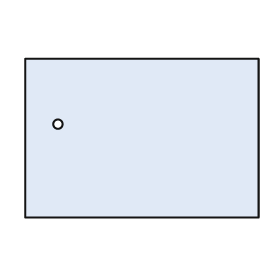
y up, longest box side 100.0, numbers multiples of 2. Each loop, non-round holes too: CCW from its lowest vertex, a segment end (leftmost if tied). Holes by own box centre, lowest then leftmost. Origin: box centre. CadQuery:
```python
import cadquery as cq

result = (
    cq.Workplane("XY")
    .moveTo(-50.0, -34.0)
    .lineTo(50.0, -34.0)
    .lineTo(50.0, 34.0)
    .lineTo(-50.0, 34.0)
    .close()
    .moveTo(-36.0, 6.0)
    .circle(2.0)
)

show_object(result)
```